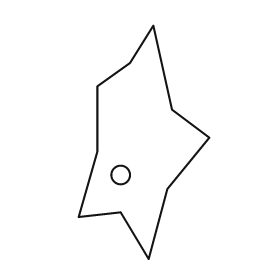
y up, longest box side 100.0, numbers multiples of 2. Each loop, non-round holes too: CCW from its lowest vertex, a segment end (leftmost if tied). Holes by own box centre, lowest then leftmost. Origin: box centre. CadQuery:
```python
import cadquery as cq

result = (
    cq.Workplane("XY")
    .moveTo(2.0, -50.0)
    .lineTo(10.0, -20.0)
    .lineTo(28.0, 2.0)
    .lineTo(12.0, 14.0)
    .lineTo(4.0, 50.0)
    .lineTo(-6.0, 34.0)
    .lineTo(-20.0, 24.0)
    .lineTo(-20.0, -4.0)
    .lineTo(-28.0, -32.0)
    .lineTo(-10.0, -30.0)
    .close()
    .moveTo(-10.0, -14.0)
    .circle(4.0)
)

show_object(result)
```